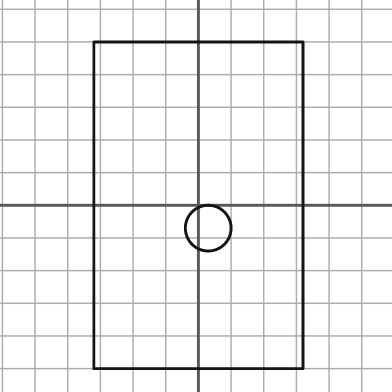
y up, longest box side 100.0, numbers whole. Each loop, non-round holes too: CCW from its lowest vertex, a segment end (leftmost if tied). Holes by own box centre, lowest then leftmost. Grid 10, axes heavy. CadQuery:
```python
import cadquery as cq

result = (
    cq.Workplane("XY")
    .moveTo(-32.0, -50.0)
    .lineTo(32.0, -50.0)
    .lineTo(32.0, 50.0)
    .lineTo(-32.0, 50.0)
    .close()
    .moveTo(3.0, -7.0)
    .circle(7.0)
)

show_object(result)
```